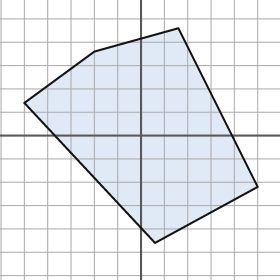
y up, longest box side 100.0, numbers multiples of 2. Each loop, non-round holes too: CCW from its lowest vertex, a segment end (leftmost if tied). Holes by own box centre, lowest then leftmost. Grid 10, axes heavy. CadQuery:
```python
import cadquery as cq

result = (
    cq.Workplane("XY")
    .moveTo(6.0, -46.0)
    .lineTo(50.0, -22.0)
    .lineTo(16.0, 46.0)
    .lineTo(-20.0, 36.0)
    .lineTo(-50.0, 14.0)
    .close()
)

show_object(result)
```